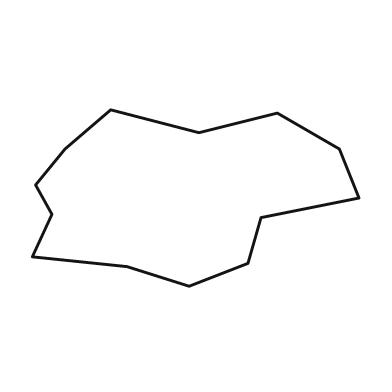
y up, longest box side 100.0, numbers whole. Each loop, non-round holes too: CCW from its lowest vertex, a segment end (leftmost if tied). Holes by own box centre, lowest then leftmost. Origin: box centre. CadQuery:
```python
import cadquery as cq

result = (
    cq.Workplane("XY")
    .moveTo(-2.0, -27.0)
    .lineTo(16.0, -20.0)
    .lineTo(20.0, -6.0)
    .lineTo(50.0, 0.0)
    .lineTo(44.0, 15.0)
    .lineTo(25.0, 26.0)
    .lineTo(1.0, 20.0)
    .lineTo(-26.0, 27.0)
    .lineTo(-40.0, 15.0)
    .lineTo(-49.0, 4.0)
    .lineTo(-44.0, -5.0)
    .lineTo(-50.0, -18.0)
    .lineTo(-21.0, -21.0)
    .close()
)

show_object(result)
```